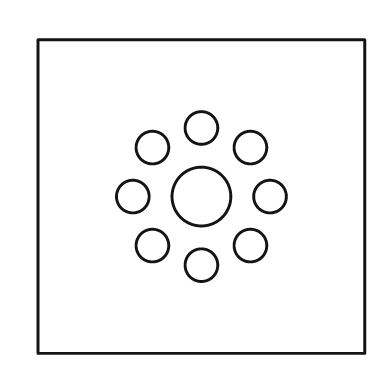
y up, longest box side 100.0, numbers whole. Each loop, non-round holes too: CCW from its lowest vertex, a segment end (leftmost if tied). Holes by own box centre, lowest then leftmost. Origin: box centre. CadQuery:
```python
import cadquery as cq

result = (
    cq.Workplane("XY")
    .moveTo(-50.0, -48.0)
    .lineTo(50.0, -48.0)
    .lineTo(50.0, 48.0)
    .lineTo(-50.0, 48.0)
    .close()
    .moveTo(0.0, -21.0)
    .circle(5.0)
    .moveTo(-15.0, -15.0)
    .circle(5.0)
    .moveTo(15.0, -15.0)
    .circle(5.0)
    .moveTo(-21.0, 0.0)
    .circle(5.0)
    .moveTo(0.0, 0.0)
    .circle(9.0)
    .moveTo(21.0, 0.0)
    .circle(5.0)
    .moveTo(-15.0, 15.0)
    .circle(5.0)
    .moveTo(15.0, 15.0)
    .circle(5.0)
    .moveTo(0.0, 21.0)
    .circle(5.0)
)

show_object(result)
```